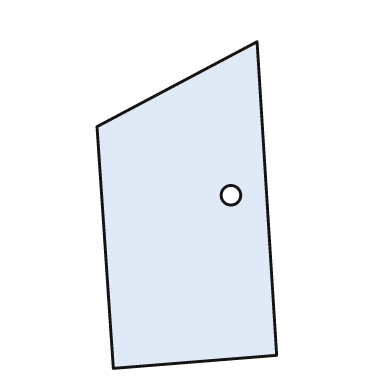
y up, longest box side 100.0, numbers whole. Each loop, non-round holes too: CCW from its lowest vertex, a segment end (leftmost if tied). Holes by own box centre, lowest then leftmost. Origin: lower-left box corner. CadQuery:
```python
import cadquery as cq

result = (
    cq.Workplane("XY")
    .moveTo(5.0, 0.0)
    .lineTo(55.0, 4.0)
    .lineTo(49.0, 100.0)
    .lineTo(0.0, 74.0)
    .close()
    .moveTo(41.0, 53.0)
    .circle(3.0)
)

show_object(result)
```